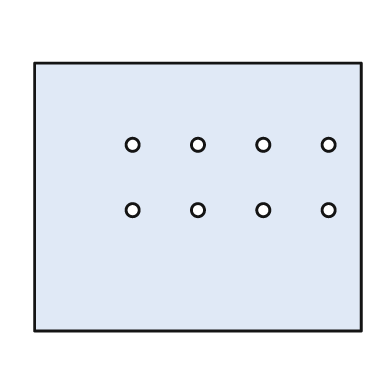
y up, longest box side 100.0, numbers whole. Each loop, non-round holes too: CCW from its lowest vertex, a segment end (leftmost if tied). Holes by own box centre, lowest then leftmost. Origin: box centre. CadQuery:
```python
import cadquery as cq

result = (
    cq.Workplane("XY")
    .moveTo(-50.0, -41.0)
    .lineTo(50.0, -41.0)
    .lineTo(50.0, 41.0)
    .lineTo(-50.0, 41.0)
    .close()
    .moveTo(-20.0, -4.0)
    .circle(2.0)
    .moveTo(0.0, -4.0)
    .circle(2.0)
    .moveTo(20.0, -4.0)
    .circle(2.0)
    .moveTo(40.0, -4.0)
    .circle(2.0)
    .moveTo(-20.0, 16.0)
    .circle(2.0)
    .moveTo(0.0, 16.0)
    .circle(2.0)
    .moveTo(20.0, 16.0)
    .circle(2.0)
    .moveTo(40.0, 16.0)
    .circle(2.0)
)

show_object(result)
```